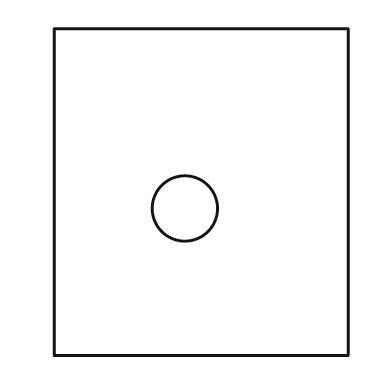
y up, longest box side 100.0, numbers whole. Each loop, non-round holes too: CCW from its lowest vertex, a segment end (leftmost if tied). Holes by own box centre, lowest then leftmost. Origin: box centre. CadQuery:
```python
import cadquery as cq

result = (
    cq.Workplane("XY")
    .moveTo(-45.0, -50.0)
    .lineTo(45.0, -50.0)
    .lineTo(45.0, 50.0)
    .lineTo(-45.0, 50.0)
    .close()
    .moveTo(-5.0, -5.0)
    .circle(10.0)
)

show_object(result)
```